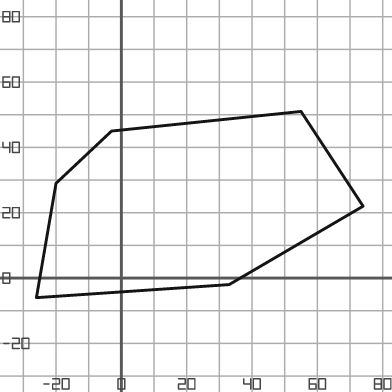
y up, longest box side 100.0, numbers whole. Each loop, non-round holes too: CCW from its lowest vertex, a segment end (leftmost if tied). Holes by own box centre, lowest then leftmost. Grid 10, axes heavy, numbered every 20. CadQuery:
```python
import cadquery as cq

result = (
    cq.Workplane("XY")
    .moveTo(-26.0, -6.0)
    .lineTo(33.0, -2.0)
    .lineTo(74.0, 22.0)
    .lineTo(55.0, 51.0)
    .lineTo(-3.0, 45.0)
    .lineTo(-20.0, 29.0)
    .close()
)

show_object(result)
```